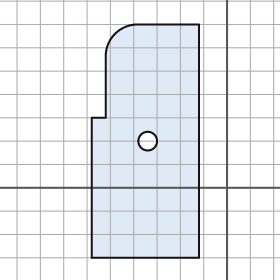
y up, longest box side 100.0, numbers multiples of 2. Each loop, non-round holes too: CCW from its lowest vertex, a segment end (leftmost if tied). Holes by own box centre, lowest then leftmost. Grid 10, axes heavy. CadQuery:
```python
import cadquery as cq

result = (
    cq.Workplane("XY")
    .moveTo(-58.0, -30.0)
    .lineTo(-12.0, -30.0)
    .lineTo(-12.0, 70.0)
    .lineTo(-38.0, 70.0)
    .threePointArc((-48.0, 66.0), (-52.0, 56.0))
    .lineTo(-52.0, 30.0)
    .lineTo(-58.0, 30.0)
    .close()
    .moveTo(-34.0, 20.0)
    .circle(4.0)
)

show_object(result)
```